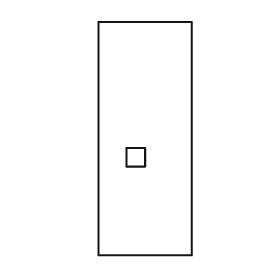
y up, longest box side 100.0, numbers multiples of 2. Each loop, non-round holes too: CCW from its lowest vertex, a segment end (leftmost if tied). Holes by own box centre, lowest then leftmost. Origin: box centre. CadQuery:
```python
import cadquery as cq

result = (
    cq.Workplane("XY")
    .moveTo(-20.0, -50.0)
    .lineTo(20.0, -50.0)
    .lineTo(20.0, 50.0)
    .lineTo(-20.0, 50.0)
    .close()
    .moveTo(-8.0, -12.0)
    .lineTo(0.0, -12.0)
    .lineTo(0.0, -4.0)
    .lineTo(-8.0, -4.0)
    .close()
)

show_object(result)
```